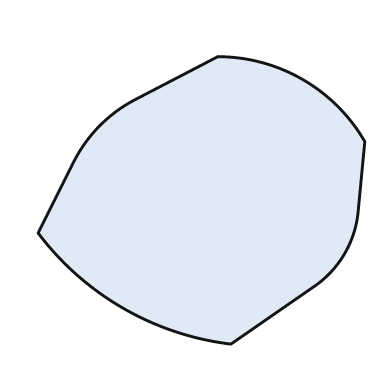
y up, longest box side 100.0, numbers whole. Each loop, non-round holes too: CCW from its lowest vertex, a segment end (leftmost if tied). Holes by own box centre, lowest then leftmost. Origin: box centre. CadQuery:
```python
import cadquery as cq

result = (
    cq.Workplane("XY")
    .moveTo(9.0, -44.0)
    .lineTo(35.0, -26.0)
    .threePointArc((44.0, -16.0), (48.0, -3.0))
    .lineTo(50.0, 18.0)
    .threePointArc((31.0, 37.0), (5.0, 44.0))
    .lineTo(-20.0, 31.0)
    .threePointArc((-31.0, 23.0), (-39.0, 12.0))
    .lineTo(-50.0, -10.0)
    .threePointArc((-24.0, -33.0), (9.0, -44.0))
    .close()
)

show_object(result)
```